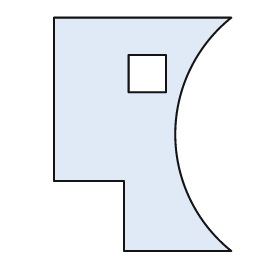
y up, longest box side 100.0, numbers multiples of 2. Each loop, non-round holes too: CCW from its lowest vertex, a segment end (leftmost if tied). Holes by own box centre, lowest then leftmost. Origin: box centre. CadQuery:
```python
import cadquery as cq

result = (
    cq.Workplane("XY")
    .moveTo(-8.0, -50.0)
    .lineTo(38.0, -50.0)
    .threePointArc((14.0, 0.0), (38.0, 50.0))
    .lineTo(-38.0, 50.0)
    .lineTo(-38.0, -20.0)
    .lineTo(-8.0, -20.0)
    .close()
    .moveTo(-6.0, 18.0)
    .lineTo(10.0, 18.0)
    .lineTo(10.0, 34.0)
    .lineTo(-6.0, 34.0)
    .close()
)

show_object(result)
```